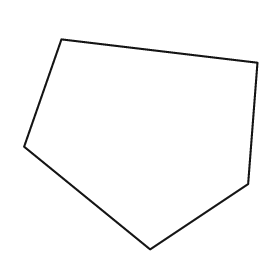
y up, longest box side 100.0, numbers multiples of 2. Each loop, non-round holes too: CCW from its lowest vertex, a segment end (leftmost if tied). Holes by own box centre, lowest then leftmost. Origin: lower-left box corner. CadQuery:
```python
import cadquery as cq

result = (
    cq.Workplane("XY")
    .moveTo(54.0, 0.0)
    .lineTo(96.0, 28.0)
    .lineTo(100.0, 80.0)
    .lineTo(16.0, 90.0)
    .lineTo(0.0, 44.0)
    .close()
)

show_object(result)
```